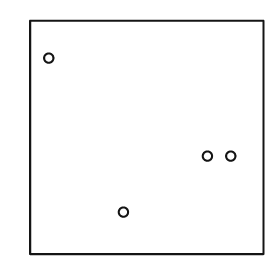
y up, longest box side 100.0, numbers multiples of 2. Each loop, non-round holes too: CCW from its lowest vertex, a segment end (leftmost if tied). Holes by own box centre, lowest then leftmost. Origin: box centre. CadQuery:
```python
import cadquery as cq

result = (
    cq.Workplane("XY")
    .moveTo(-50.0, -50.0)
    .lineTo(50.0, -50.0)
    .lineTo(50.0, 50.0)
    .lineTo(-50.0, 50.0)
    .close()
    .moveTo(-10.0, -32.0)
    .circle(2.0)
    .moveTo(26.0, -8.0)
    .circle(2.0)
    .moveTo(36.0, -8.0)
    .circle(2.0)
    .moveTo(-42.0, 34.0)
    .circle(2.0)
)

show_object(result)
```